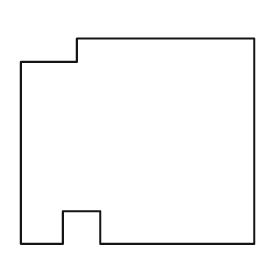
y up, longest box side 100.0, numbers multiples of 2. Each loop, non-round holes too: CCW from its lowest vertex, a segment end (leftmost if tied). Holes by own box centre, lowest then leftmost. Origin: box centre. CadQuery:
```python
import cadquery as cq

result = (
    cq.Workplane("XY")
    .moveTo(-50.0, -44.0)
    .lineTo(-32.0, -44.0)
    .lineTo(-32.0, -30.0)
    .lineTo(-16.0, -30.0)
    .lineTo(-16.0, -44.0)
    .lineTo(50.0, -44.0)
    .lineTo(50.0, 44.0)
    .lineTo(-26.0, 44.0)
    .lineTo(-26.0, 34.0)
    .lineTo(-50.0, 34.0)
    .close()
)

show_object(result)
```